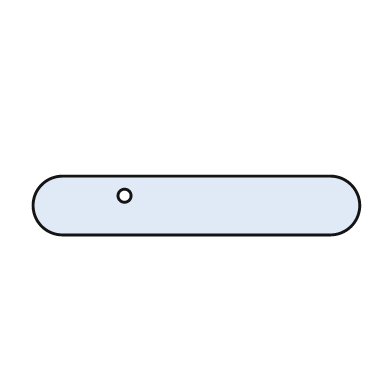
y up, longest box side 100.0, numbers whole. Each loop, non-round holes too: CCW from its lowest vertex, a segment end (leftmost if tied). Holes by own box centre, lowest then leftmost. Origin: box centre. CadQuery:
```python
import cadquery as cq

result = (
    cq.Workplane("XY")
    .moveTo(-41.0, -9.0)
    .lineTo(41.0, -9.0)
    .threePointArc((50.0, 0.0), (41.0, 9.0))
    .lineTo(-41.0, 9.0)
    .threePointArc((-50.0, 0.0), (-41.0, -9.0))
    .close()
    .moveTo(-22.0, 3.0)
    .circle(2.0)
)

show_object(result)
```